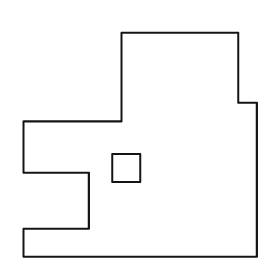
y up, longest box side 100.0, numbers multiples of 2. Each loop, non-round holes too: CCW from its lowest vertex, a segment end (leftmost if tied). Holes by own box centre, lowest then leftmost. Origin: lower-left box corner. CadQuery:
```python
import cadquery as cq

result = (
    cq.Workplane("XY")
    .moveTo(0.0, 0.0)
    .lineTo(100.0, 0.0)
    .lineTo(100.0, 66.0)
    .lineTo(92.0, 66.0)
    .lineTo(92.0, 96.0)
    .lineTo(42.0, 96.0)
    .lineTo(42.0, 58.0)
    .lineTo(0.0, 58.0)
    .lineTo(0.0, 36.0)
    .lineTo(28.0, 36.0)
    .lineTo(28.0, 12.0)
    .lineTo(0.0, 12.0)
    .close()
    .moveTo(38.0, 32.0)
    .lineTo(50.0, 32.0)
    .lineTo(50.0, 44.0)
    .lineTo(38.0, 44.0)
    .close()
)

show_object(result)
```